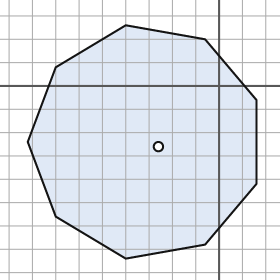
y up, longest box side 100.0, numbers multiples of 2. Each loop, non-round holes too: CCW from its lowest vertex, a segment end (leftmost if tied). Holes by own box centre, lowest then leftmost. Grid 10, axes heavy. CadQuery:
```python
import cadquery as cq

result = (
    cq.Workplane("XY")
    .moveTo(-40.0, -74.0)
    .lineTo(-6.0, -68.0)
    .lineTo(16.0, -42.0)
    .lineTo(16.0, -6.0)
    .lineTo(-6.0, 20.0)
    .lineTo(-40.0, 26.0)
    .lineTo(-70.0, 8.0)
    .lineTo(-82.0, -24.0)
    .lineTo(-70.0, -56.0)
    .close()
    .moveTo(-26.0, -26.0)
    .circle(2.0)
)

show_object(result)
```